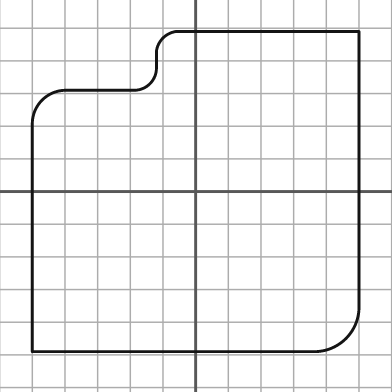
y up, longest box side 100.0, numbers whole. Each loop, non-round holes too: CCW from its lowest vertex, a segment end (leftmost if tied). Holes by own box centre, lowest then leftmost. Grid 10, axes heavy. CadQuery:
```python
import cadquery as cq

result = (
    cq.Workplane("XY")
    .moveTo(-50.0, -49.0)
    .lineTo(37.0, -49.0)
    .threePointArc((46.0, -45.0), (50.0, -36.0))
    .lineTo(50.0, 49.0)
    .lineTo(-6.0, 49.0)
    .threePointArc((-10.0, 47.0), (-12.0, 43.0))
    .lineTo(-12.0, 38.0)
    .threePointArc((-14.0, 33.0), (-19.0, 31.0))
    .lineTo(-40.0, 31.0)
    .threePointArc((-47.0, 28.0), (-50.0, 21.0))
    .close()
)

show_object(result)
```